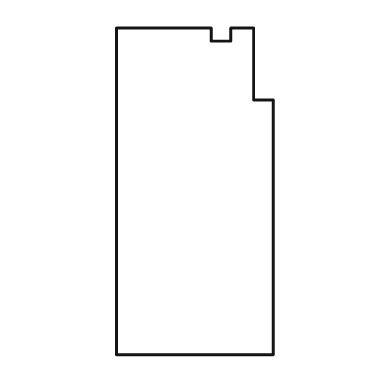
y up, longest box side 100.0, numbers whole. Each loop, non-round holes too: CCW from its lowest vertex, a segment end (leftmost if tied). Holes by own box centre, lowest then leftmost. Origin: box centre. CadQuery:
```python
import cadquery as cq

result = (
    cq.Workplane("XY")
    .moveTo(-24.0, -50.0)
    .lineTo(24.0, -50.0)
    .lineTo(24.0, 28.0)
    .lineTo(18.0, 28.0)
    .lineTo(18.0, 50.0)
    .lineTo(11.0, 50.0)
    .lineTo(11.0, 46.0)
    .lineTo(5.0, 46.0)
    .lineTo(5.0, 50.0)
    .lineTo(-24.0, 50.0)
    .close()
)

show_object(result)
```